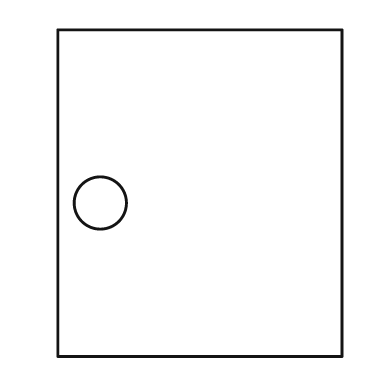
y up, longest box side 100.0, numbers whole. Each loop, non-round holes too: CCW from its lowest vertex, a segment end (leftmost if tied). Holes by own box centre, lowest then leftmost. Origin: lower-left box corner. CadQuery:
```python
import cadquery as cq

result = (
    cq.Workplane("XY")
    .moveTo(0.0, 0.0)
    .lineTo(87.0, 0.0)
    .lineTo(87.0, 100.0)
    .lineTo(0.0, 100.0)
    .close()
    .moveTo(13.0, 47.0)
    .circle(8.0)
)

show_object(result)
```